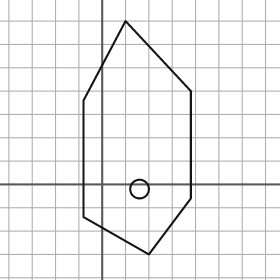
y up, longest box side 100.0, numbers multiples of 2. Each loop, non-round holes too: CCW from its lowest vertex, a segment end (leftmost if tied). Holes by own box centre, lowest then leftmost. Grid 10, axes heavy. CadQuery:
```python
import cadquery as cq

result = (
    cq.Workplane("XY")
    .moveTo(20.0, -30.0)
    .lineTo(38.0, -6.0)
    .lineTo(38.0, 40.0)
    .lineTo(10.0, 70.0)
    .lineTo(-8.0, 36.0)
    .lineTo(-8.0, -14.0)
    .close()
    .moveTo(16.0, -2.0)
    .circle(4.0)
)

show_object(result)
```